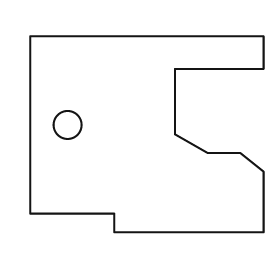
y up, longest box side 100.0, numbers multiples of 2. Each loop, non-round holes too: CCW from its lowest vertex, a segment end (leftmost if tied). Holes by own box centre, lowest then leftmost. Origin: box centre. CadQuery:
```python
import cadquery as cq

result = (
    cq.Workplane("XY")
    .moveTo(-14.0, -42.0)
    .lineTo(50.0, -42.0)
    .lineTo(50.0, -16.0)
    .lineTo(40.0, -8.0)
    .lineTo(26.0, -8.0)
    .lineTo(12.0, 0.0)
    .lineTo(12.0, 28.0)
    .lineTo(50.0, 28.0)
    .lineTo(50.0, 42.0)
    .lineTo(-50.0, 42.0)
    .lineTo(-50.0, -34.0)
    .lineTo(-14.0, -34.0)
    .close()
    .moveTo(-34.0, 4.0)
    .circle(6.0)
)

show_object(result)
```